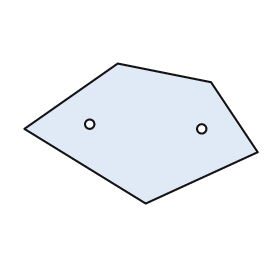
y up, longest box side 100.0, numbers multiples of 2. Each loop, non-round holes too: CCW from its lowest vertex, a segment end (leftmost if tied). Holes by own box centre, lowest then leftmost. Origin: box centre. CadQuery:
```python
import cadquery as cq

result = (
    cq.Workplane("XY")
    .moveTo(2.0, -30.0)
    .lineTo(50.0, -8.0)
    .lineTo(30.0, 22.0)
    .lineTo(-10.0, 30.0)
    .lineTo(-50.0, 2.0)
    .close()
    .moveTo(26.0, 2.0)
    .circle(2.0)
    .moveTo(-22.0, 4.0)
    .circle(2.0)
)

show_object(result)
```